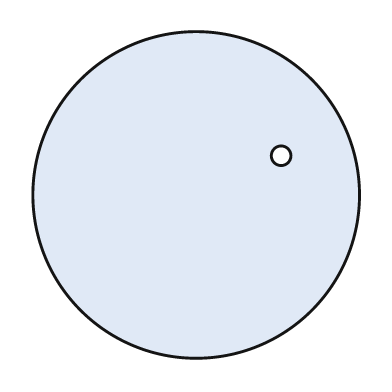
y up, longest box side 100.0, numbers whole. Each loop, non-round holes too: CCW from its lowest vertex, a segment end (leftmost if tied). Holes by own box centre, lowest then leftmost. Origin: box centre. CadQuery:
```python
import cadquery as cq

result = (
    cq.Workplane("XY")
    .moveTo(0.0, 0.0)
    .circle(50.0)
    .moveTo(26.0, 12.0)
    .circle(3.0)
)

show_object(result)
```